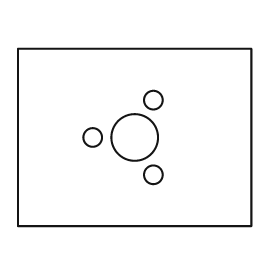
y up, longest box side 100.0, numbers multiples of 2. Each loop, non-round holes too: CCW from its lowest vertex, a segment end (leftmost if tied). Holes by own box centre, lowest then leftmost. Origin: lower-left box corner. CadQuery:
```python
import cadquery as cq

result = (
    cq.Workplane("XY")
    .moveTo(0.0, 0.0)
    .lineTo(100.0, 0.0)
    .lineTo(100.0, 76.0)
    .lineTo(0.0, 76.0)
    .close()
    .moveTo(58.0, 22.0)
    .circle(4.0)
    .moveTo(32.0, 38.0)
    .circle(4.0)
    .moveTo(50.0, 38.0)
    .circle(10.0)
    .moveTo(58.0, 54.0)
    .circle(4.0)
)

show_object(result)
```